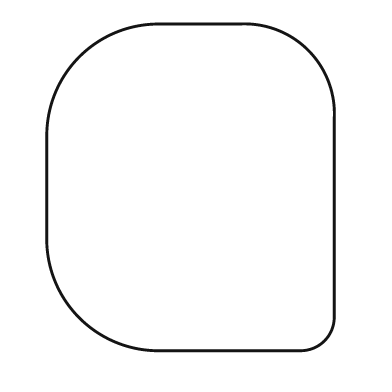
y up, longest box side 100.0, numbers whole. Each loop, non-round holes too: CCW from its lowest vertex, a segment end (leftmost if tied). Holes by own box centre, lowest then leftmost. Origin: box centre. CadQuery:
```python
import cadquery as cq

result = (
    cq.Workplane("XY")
    .moveTo(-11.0, -50.0)
    .lineTo(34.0, -50.0)
    .threePointArc((41.0, -47.0), (44.0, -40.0))
    .lineTo(44.0, 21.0)
    .threePointArc((36.0, 42.0), (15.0, 50.0))
    .lineTo(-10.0, 50.0)
    .threePointArc((-34.0, 40.0), (-44.0, 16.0))
    .lineTo(-44.0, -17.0)
    .threePointArc((-34.0, -40.0), (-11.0, -50.0))
    .close()
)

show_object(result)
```